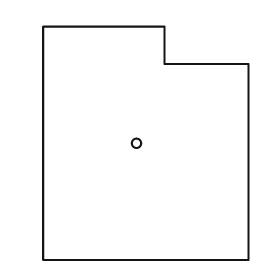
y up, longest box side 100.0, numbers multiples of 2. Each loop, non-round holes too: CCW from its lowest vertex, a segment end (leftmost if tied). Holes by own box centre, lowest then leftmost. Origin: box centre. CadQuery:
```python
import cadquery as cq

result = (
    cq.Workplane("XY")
    .moveTo(-44.0, -50.0)
    .lineTo(44.0, -50.0)
    .lineTo(44.0, 34.0)
    .lineTo(8.0, 34.0)
    .lineTo(8.0, 50.0)
    .lineTo(-44.0, 50.0)
    .close()
    .moveTo(-4.0, 0.0)
    .circle(2.0)
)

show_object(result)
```